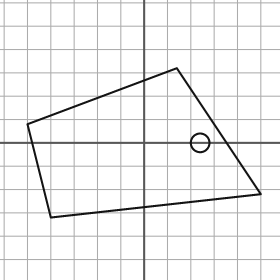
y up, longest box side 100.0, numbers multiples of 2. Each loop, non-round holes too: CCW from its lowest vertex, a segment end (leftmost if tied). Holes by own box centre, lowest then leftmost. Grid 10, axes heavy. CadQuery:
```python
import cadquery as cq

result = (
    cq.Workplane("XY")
    .moveTo(-40.0, -32.0)
    .lineTo(50.0, -22.0)
    .lineTo(14.0, 32.0)
    .lineTo(-50.0, 8.0)
    .close()
    .moveTo(24.0, 0.0)
    .circle(4.0)
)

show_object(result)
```